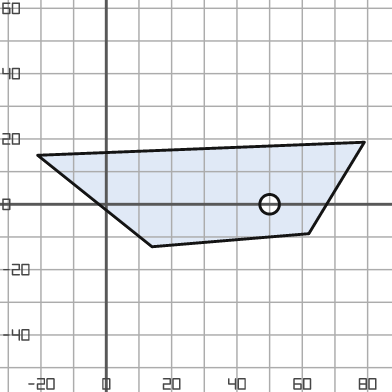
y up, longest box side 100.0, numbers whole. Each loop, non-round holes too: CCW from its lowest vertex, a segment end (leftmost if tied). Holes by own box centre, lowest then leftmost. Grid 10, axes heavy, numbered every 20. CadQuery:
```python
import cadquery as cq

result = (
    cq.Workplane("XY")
    .moveTo(14.0, -13.0)
    .lineTo(62.0, -9.0)
    .lineTo(79.0, 19.0)
    .lineTo(-21.0, 15.0)
    .close()
    .moveTo(50.0, 0.0)
    .circle(3.0)
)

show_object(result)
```